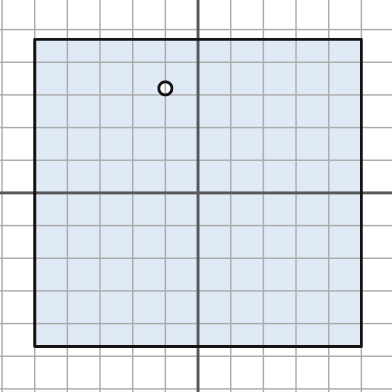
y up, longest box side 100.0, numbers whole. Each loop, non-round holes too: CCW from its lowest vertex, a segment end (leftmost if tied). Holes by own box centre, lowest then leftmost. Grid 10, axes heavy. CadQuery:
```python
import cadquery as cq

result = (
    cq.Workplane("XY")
    .moveTo(-50.0, -47.0)
    .lineTo(50.0, -47.0)
    .lineTo(50.0, 47.0)
    .lineTo(-50.0, 47.0)
    .close()
    .moveTo(-10.0, 32.0)
    .circle(2.0)
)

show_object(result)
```